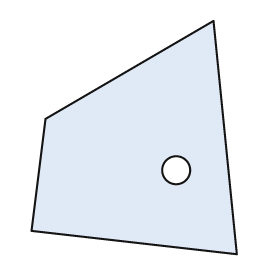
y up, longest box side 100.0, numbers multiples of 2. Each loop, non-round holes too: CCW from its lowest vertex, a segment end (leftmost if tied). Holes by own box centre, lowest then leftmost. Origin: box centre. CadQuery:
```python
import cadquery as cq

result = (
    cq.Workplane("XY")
    .moveTo(44.0, -50.0)
    .lineTo(34.0, 50.0)
    .lineTo(-38.0, 8.0)
    .lineTo(-44.0, -40.0)
    .close()
    .moveTo(18.0, -14.0)
    .circle(6.0)
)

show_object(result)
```